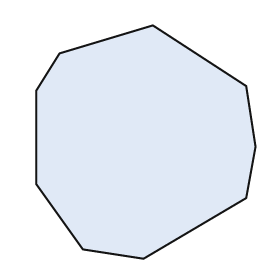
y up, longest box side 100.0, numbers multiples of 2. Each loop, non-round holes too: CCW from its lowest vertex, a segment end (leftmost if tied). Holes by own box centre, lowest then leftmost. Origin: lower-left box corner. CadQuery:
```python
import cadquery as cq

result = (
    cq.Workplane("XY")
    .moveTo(46.0, 0.0)
    .lineTo(90.0, 26.0)
    .lineTo(94.0, 48.0)
    .lineTo(90.0, 74.0)
    .lineTo(50.0, 100.0)
    .lineTo(10.0, 88.0)
    .lineTo(0.0, 72.0)
    .lineTo(0.0, 32.0)
    .lineTo(20.0, 4.0)
    .close()
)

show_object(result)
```